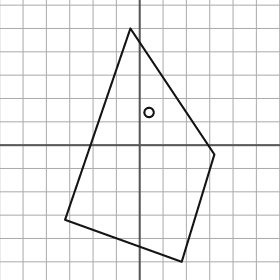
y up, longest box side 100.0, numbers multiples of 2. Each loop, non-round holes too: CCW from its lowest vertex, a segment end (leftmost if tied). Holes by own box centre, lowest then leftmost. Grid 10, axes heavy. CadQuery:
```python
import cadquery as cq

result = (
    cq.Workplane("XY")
    .moveTo(18.0, -50.0)
    .lineTo(32.0, -4.0)
    .lineTo(-4.0, 50.0)
    .lineTo(-32.0, -32.0)
    .close()
    .moveTo(4.0, 14.0)
    .circle(2.0)
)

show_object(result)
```